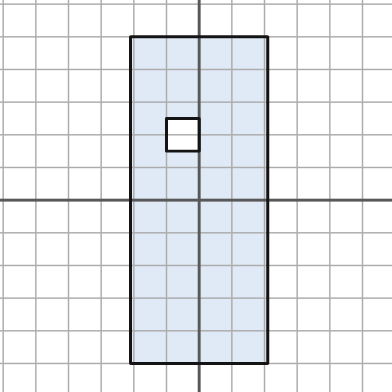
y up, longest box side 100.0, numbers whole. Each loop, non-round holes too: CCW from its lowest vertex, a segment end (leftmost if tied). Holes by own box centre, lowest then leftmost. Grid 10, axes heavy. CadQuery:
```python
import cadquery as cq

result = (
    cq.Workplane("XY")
    .moveTo(-21.0, -50.0)
    .lineTo(21.0, -50.0)
    .lineTo(21.0, 50.0)
    .lineTo(-21.0, 50.0)
    .close()
    .moveTo(-10.0, 15.0)
    .lineTo(0.0, 15.0)
    .lineTo(0.0, 25.0)
    .lineTo(-10.0, 25.0)
    .close()
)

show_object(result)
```